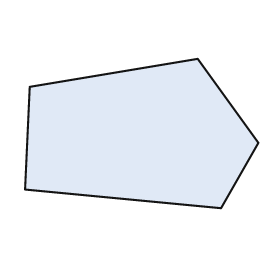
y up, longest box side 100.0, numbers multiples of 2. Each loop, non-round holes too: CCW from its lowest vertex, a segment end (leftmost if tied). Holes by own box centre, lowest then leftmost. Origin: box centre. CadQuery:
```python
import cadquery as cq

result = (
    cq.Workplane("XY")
    .moveTo(34.0, -32.0)
    .lineTo(50.0, -4.0)
    .lineTo(24.0, 32.0)
    .lineTo(-48.0, 20.0)
    .lineTo(-50.0, -24.0)
    .close()
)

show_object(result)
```